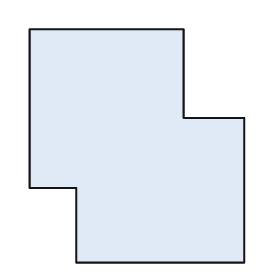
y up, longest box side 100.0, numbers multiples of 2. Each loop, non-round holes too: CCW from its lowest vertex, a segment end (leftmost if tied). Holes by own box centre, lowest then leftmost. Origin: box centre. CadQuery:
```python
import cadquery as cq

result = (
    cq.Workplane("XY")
    .moveTo(-26.0, -50.0)
    .lineTo(46.0, -50.0)
    .lineTo(46.0, 12.0)
    .lineTo(20.0, 12.0)
    .lineTo(20.0, 50.0)
    .lineTo(-46.0, 50.0)
    .lineTo(-46.0, -18.0)
    .lineTo(-26.0, -18.0)
    .close()
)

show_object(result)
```